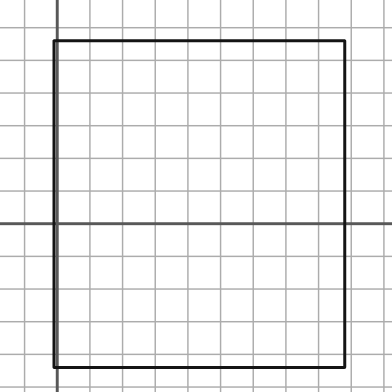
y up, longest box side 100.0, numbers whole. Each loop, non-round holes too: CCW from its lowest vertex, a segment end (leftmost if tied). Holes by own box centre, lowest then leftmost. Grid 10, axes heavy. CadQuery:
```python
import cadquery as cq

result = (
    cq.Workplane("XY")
    .moveTo(-1.0, -44.0)
    .lineTo(88.0, -44.0)
    .lineTo(88.0, 56.0)
    .lineTo(-1.0, 56.0)
    .close()
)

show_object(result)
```